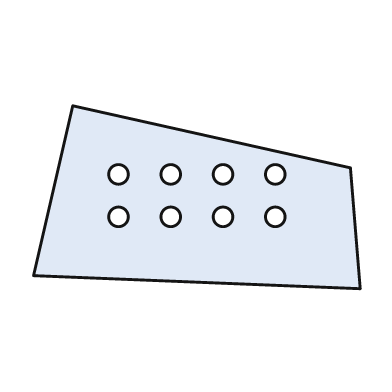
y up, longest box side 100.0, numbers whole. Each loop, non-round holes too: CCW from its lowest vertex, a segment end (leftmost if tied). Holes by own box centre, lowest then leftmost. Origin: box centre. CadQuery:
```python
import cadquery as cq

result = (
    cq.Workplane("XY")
    .moveTo(50.0, -28.0)
    .lineTo(47.0, 9.0)
    .lineTo(-38.0, 28.0)
    .lineTo(-50.0, -24.0)
    .close()
    .moveTo(-24.0, -6.0)
    .circle(3.0)
    .moveTo(-8.0, -6.0)
    .circle(3.0)
    .moveTo(8.0, -6.0)
    .circle(3.0)
    .moveTo(24.0, -6.0)
    .circle(3.0)
    .moveTo(-24.0, 7.0)
    .circle(3.0)
    .moveTo(-8.0, 7.0)
    .circle(3.0)
    .moveTo(8.0, 7.0)
    .circle(3.0)
    .moveTo(24.0, 7.0)
    .circle(3.0)
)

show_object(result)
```